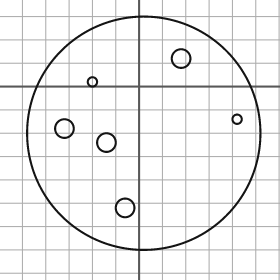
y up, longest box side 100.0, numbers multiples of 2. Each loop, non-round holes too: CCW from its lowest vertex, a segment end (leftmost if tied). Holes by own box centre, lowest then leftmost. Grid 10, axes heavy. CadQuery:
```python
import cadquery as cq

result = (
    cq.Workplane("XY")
    .moveTo(2.0, -20.0)
    .circle(50.0)
    .moveTo(-6.0, -52.0)
    .circle(4.0)
    .moveTo(-14.0, -24.0)
    .circle(4.0)
    .moveTo(-32.0, -18.0)
    .circle(4.0)
    .moveTo(42.0, -14.0)
    .circle(2.0)
    .moveTo(-20.0, 2.0)
    .circle(2.0)
    .moveTo(18.0, 12.0)
    .circle(4.0)
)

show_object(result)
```